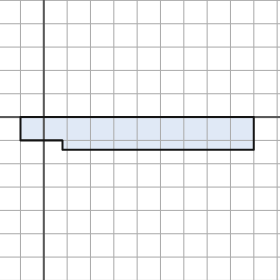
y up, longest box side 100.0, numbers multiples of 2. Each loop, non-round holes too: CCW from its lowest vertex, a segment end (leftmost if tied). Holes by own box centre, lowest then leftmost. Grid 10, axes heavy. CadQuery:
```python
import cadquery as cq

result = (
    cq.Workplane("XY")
    .moveTo(8.0, -14.0)
    .lineTo(90.0, -14.0)
    .lineTo(90.0, 0.0)
    .lineTo(-10.0, 0.0)
    .lineTo(-10.0, -10.0)
    .lineTo(8.0, -10.0)
    .close()
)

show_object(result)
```